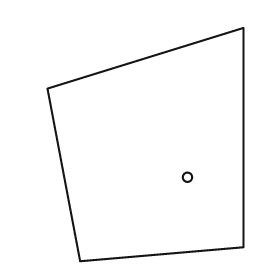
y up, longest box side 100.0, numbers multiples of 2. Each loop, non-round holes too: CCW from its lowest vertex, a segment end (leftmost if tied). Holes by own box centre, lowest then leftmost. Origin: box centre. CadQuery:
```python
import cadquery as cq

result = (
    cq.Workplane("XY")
    .moveTo(-28.0, -50.0)
    .lineTo(42.0, -44.0)
    .lineTo(42.0, 50.0)
    .lineTo(-42.0, 24.0)
    .close()
    .moveTo(18.0, -14.0)
    .circle(2.0)
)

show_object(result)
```